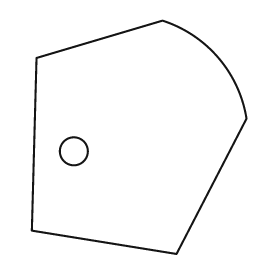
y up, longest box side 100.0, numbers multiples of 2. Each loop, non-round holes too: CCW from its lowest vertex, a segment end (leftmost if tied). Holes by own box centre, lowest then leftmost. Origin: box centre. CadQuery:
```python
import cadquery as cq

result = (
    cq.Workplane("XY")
    .moveTo(16.0, -50.0)
    .lineTo(46.0, 8.0)
    .threePointArc((34.0, 34.0), (10.0, 50.0))
    .lineTo(-44.0, 34.0)
    .lineTo(-46.0, -40.0)
    .close()
    .moveTo(-28.0, -6.0)
    .circle(6.0)
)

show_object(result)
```